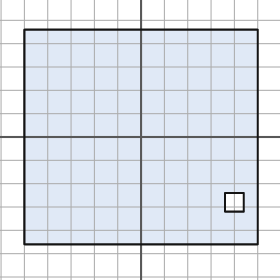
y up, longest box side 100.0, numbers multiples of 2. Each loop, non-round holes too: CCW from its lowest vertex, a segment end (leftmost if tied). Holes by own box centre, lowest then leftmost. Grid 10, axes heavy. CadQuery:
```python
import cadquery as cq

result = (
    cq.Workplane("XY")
    .moveTo(-50.0, -46.0)
    .lineTo(50.0, -46.0)
    .lineTo(50.0, 46.0)
    .lineTo(-50.0, 46.0)
    .close()
    .moveTo(36.0, -32.0)
    .lineTo(44.0, -32.0)
    .lineTo(44.0, -24.0)
    .lineTo(36.0, -24.0)
    .close()
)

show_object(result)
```